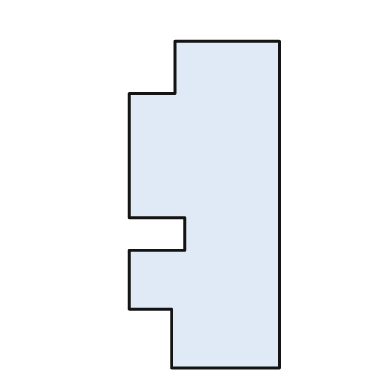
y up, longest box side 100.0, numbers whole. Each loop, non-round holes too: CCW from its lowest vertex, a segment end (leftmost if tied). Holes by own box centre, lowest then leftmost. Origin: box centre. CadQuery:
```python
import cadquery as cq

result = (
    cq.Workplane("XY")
    .moveTo(-10.0, -50.0)
    .lineTo(23.0, -50.0)
    .lineTo(23.0, 50.0)
    .lineTo(-9.0, 50.0)
    .lineTo(-9.0, 34.0)
    .lineTo(-23.0, 34.0)
    .lineTo(-23.0, -4.0)
    .lineTo(-6.0, -4.0)
    .lineTo(-6.0, -14.0)
    .lineTo(-23.0, -14.0)
    .lineTo(-23.0, -32.0)
    .lineTo(-10.0, -32.0)
    .close()
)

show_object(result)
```